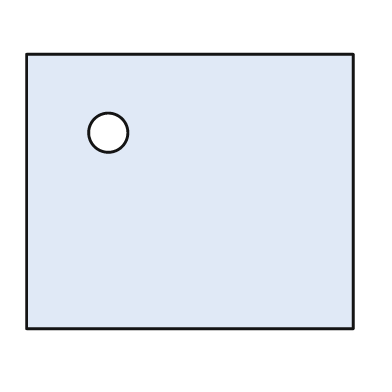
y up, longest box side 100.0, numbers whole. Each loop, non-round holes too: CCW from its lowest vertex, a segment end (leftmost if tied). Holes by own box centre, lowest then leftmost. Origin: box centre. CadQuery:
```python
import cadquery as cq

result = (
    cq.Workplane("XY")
    .moveTo(-50.0, -42.0)
    .lineTo(50.0, -42.0)
    .lineTo(50.0, 42.0)
    .lineTo(-50.0, 42.0)
    .close()
    .moveTo(-25.0, 18.0)
    .circle(6.0)
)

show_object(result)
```